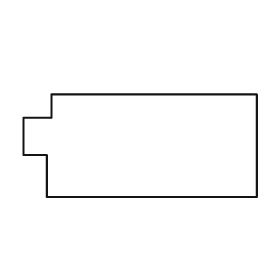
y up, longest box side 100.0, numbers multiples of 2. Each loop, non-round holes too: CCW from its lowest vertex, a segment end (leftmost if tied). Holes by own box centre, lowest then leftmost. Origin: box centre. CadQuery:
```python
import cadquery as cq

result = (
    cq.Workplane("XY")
    .moveTo(-40.0, -22.0)
    .lineTo(50.0, -22.0)
    .lineTo(50.0, 22.0)
    .lineTo(-38.0, 22.0)
    .lineTo(-38.0, 12.0)
    .lineTo(-50.0, 12.0)
    .lineTo(-50.0, -4.0)
    .lineTo(-40.0, -4.0)
    .close()
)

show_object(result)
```